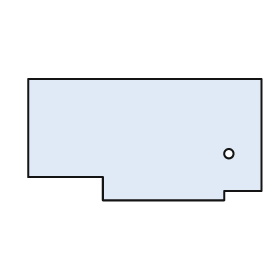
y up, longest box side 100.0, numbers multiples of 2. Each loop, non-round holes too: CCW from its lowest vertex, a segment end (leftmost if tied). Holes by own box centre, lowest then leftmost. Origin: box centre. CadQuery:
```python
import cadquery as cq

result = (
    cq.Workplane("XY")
    .moveTo(-18.0, -26.0)
    .lineTo(34.0, -26.0)
    .lineTo(34.0, -22.0)
    .lineTo(50.0, -22.0)
    .lineTo(50.0, 26.0)
    .lineTo(-50.0, 26.0)
    .lineTo(-50.0, -16.0)
    .lineTo(-18.0, -16.0)
    .close()
    .moveTo(36.0, -6.0)
    .circle(2.0)
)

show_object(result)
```